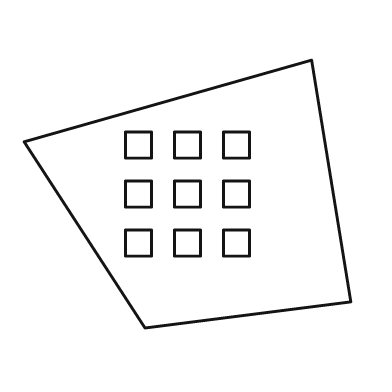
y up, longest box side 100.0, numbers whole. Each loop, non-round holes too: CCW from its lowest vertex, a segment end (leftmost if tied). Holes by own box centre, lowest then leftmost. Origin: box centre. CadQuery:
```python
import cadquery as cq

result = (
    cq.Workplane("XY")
    .moveTo(-13.0, -41.0)
    .lineTo(50.0, -33.0)
    .lineTo(38.0, 41.0)
    .lineTo(-50.0, 16.0)
    .close()
    .moveTo(-19.0, -19.0)
    .lineTo(-11.0, -19.0)
    .lineTo(-11.0, -11.0)
    .lineTo(-19.0, -11.0)
    .close()
    .moveTo(-4.0, -19.0)
    .lineTo(4.0, -19.0)
    .lineTo(4.0, -11.0)
    .lineTo(-4.0, -11.0)
    .close()
    .moveTo(11.0, -19.0)
    .lineTo(19.0, -19.0)
    .lineTo(19.0, -11.0)
    .lineTo(11.0, -11.0)
    .close()
    .moveTo(-19.0, -4.0)
    .lineTo(-11.0, -4.0)
    .lineTo(-11.0, 4.0)
    .lineTo(-19.0, 4.0)
    .close()
    .moveTo(-4.0, -4.0)
    .lineTo(4.0, -4.0)
    .lineTo(4.0, 4.0)
    .lineTo(-4.0, 4.0)
    .close()
    .moveTo(11.0, -4.0)
    .lineTo(19.0, -4.0)
    .lineTo(19.0, 4.0)
    .lineTo(11.0, 4.0)
    .close()
    .moveTo(-19.0, 11.0)
    .lineTo(-11.0, 11.0)
    .lineTo(-11.0, 19.0)
    .lineTo(-19.0, 19.0)
    .close()
    .moveTo(-4.0, 11.0)
    .lineTo(4.0, 11.0)
    .lineTo(4.0, 19.0)
    .lineTo(-4.0, 19.0)
    .close()
    .moveTo(11.0, 11.0)
    .lineTo(19.0, 11.0)
    .lineTo(19.0, 19.0)
    .lineTo(11.0, 19.0)
    .close()
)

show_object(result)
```